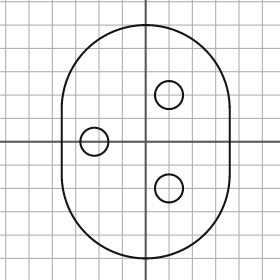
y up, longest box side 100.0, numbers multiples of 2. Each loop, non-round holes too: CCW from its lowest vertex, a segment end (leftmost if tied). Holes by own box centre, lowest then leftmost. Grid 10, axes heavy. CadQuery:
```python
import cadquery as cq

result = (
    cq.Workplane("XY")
    .moveTo(-36.0, -14.0)
    .threePointArc((0.0, -50.0), (36.0, -14.0))
    .lineTo(36.0, 14.0)
    .threePointArc((0.0, 50.0), (-36.0, 14.0))
    .close()
    .moveTo(10.0, -20.0)
    .circle(6.0)
    .moveTo(-22.0, 0.0)
    .circle(6.0)
    .moveTo(10.0, 20.0)
    .circle(6.0)
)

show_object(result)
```